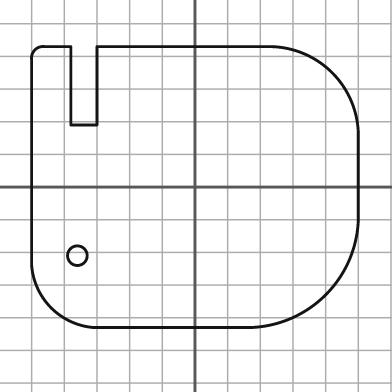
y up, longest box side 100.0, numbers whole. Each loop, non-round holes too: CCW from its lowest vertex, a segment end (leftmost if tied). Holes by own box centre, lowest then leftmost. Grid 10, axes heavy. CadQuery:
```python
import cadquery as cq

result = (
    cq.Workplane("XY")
    .moveTo(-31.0, -43.0)
    .lineTo(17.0, -43.0)
    .threePointArc((40.0, -33.0), (50.0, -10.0))
    .lineTo(50.0, 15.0)
    .threePointArc((42.0, 35.0), (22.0, 43.0))
    .lineTo(-30.0, 43.0)
    .lineTo(-30.0, 19.0)
    .lineTo(-38.0, 19.0)
    .lineTo(-38.0, 43.0)
    .lineTo(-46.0, 43.0)
    .threePointArc((-49.0, 42.0), (-50.0, 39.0))
    .lineTo(-50.0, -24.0)
    .threePointArc((-44.0, -37.0), (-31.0, -43.0))
    .close()
    .moveTo(-36.0, -21.0)
    .circle(3.0)
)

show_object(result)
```